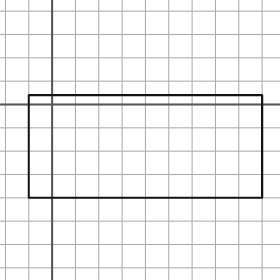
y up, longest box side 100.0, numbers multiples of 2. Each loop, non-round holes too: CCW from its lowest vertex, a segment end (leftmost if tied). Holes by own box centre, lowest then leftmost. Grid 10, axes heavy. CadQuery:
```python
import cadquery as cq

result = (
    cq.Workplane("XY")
    .moveTo(-10.0, -40.0)
    .lineTo(90.0, -40.0)
    .lineTo(90.0, 4.0)
    .lineTo(-10.0, 4.0)
    .close()
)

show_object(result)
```